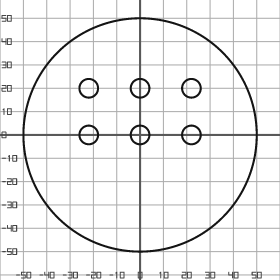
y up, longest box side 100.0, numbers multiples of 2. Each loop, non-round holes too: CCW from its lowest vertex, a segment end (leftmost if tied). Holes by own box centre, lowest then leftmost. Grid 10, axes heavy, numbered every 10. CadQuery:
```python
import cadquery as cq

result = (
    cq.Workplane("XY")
    .moveTo(0.0, 0.0)
    .circle(50.0)
    .moveTo(-22.0, 0.0)
    .circle(4.0)
    .moveTo(0.0, 0.0)
    .circle(4.0)
    .moveTo(22.0, 0.0)
    .circle(4.0)
    .moveTo(-22.0, 20.0)
    .circle(4.0)
    .moveTo(0.0, 20.0)
    .circle(4.0)
    .moveTo(22.0, 20.0)
    .circle(4.0)
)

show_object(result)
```